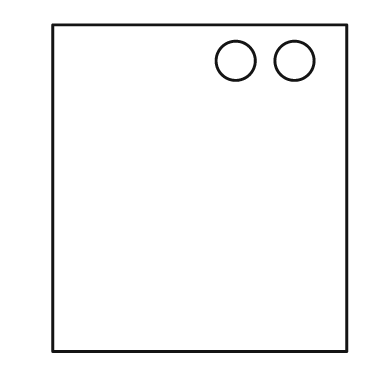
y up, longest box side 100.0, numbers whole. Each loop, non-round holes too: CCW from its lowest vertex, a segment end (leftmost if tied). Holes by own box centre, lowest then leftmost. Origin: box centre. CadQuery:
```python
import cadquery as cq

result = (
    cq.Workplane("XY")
    .moveTo(-45.0, -50.0)
    .lineTo(45.0, -50.0)
    .lineTo(45.0, 50.0)
    .lineTo(-45.0, 50.0)
    .close()
    .moveTo(11.0, 39.0)
    .circle(6.0)
    .moveTo(29.0, 39.0)
    .circle(6.0)
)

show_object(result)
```